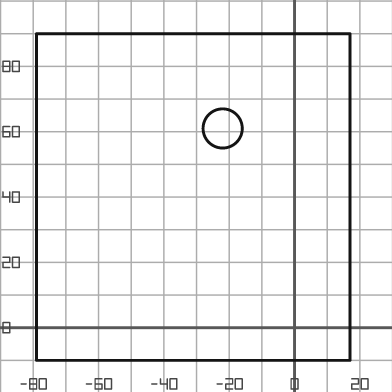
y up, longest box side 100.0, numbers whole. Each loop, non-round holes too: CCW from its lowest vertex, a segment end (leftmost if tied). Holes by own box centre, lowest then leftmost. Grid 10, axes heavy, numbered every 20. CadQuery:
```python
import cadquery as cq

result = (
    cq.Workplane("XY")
    .moveTo(-79.0, -10.0)
    .lineTo(17.0, -10.0)
    .lineTo(17.0, 90.0)
    .lineTo(-79.0, 90.0)
    .close()
    .moveTo(-22.0, 61.0)
    .circle(6.0)
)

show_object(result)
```